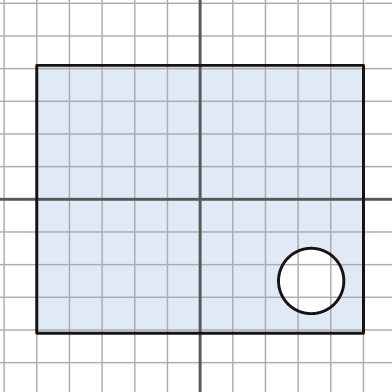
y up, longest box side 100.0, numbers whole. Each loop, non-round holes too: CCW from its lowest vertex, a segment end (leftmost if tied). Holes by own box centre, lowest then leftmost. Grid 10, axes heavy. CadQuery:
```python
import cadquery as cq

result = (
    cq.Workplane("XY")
    .moveTo(-50.0, -41.0)
    .lineTo(50.0, -41.0)
    .lineTo(50.0, 41.0)
    .lineTo(-50.0, 41.0)
    .close()
    .moveTo(34.0, -25.0)
    .circle(10.0)
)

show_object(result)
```